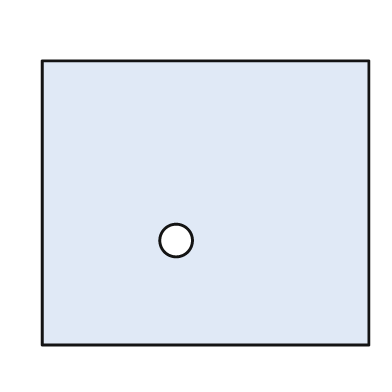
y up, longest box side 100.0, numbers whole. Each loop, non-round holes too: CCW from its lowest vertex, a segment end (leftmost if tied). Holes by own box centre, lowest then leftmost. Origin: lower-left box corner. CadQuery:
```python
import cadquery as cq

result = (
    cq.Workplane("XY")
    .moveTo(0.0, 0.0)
    .lineTo(100.0, 0.0)
    .lineTo(100.0, 87.0)
    .lineTo(0.0, 87.0)
    .close()
    .moveTo(41.0, 32.0)
    .circle(5.0)
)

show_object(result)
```